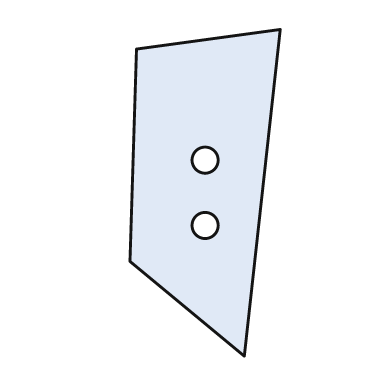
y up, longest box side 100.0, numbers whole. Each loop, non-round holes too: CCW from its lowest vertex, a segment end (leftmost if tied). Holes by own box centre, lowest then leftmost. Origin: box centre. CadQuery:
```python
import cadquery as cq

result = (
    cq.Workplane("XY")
    .moveTo(12.0, -50.0)
    .lineTo(23.0, 50.0)
    .lineTo(-21.0, 44.0)
    .lineTo(-23.0, -21.0)
    .close()
    .moveTo(0.0, -10.0)
    .circle(4.0)
    .moveTo(0.0, 10.0)
    .circle(4.0)
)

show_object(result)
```